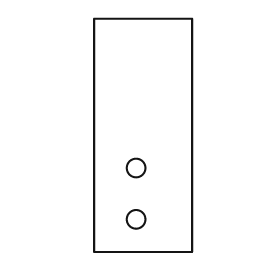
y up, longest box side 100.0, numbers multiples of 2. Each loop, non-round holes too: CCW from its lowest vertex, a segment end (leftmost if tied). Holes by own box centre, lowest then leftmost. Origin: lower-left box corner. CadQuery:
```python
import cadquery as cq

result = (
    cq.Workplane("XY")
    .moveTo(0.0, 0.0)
    .lineTo(42.0, 0.0)
    .lineTo(42.0, 100.0)
    .lineTo(0.0, 100.0)
    .close()
    .moveTo(18.0, 14.0)
    .circle(4.0)
    .moveTo(18.0, 36.0)
    .circle(4.0)
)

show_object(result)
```